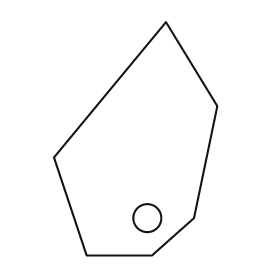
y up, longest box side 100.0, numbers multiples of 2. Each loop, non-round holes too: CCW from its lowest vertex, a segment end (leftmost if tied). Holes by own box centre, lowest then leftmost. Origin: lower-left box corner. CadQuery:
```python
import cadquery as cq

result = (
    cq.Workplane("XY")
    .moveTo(14.0, 0.0)
    .lineTo(42.0, 0.0)
    .lineTo(60.0, 16.0)
    .lineTo(70.0, 64.0)
    .lineTo(48.0, 100.0)
    .lineTo(0.0, 42.0)
    .close()
    .moveTo(40.0, 16.0)
    .circle(6.0)
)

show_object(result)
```